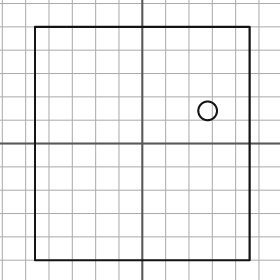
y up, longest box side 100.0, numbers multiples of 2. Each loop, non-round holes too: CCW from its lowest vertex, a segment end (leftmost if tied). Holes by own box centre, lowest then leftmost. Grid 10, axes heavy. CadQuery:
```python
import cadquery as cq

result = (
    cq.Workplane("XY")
    .moveTo(-46.0, -50.0)
    .lineTo(46.0, -50.0)
    .lineTo(46.0, 50.0)
    .lineTo(-46.0, 50.0)
    .close()
    .moveTo(28.0, 14.0)
    .circle(4.0)
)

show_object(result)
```